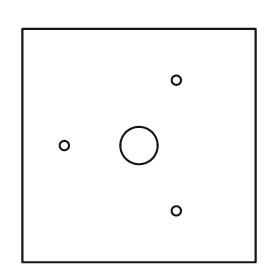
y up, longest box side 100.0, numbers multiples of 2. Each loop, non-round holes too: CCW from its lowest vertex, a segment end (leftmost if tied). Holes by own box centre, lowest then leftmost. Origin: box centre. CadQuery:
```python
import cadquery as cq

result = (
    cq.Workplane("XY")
    .moveTo(-50.0, -50.0)
    .lineTo(50.0, -50.0)
    .lineTo(50.0, 50.0)
    .lineTo(-50.0, 50.0)
    .close()
    .moveTo(16.0, -28.0)
    .circle(2.0)
    .moveTo(-32.0, 0.0)
    .circle(2.0)
    .moveTo(0.0, 0.0)
    .circle(8.0)
    .moveTo(16.0, 28.0)
    .circle(2.0)
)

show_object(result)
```